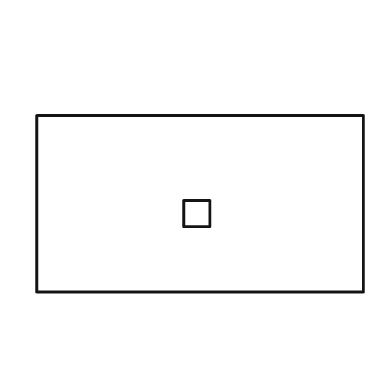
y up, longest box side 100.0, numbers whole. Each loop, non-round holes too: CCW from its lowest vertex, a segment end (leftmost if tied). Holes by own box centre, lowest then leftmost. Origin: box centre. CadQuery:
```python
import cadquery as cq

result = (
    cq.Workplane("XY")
    .moveTo(-50.0, -27.0)
    .lineTo(50.0, -27.0)
    .lineTo(50.0, 27.0)
    .lineTo(-50.0, 27.0)
    .close()
    .moveTo(-5.0, -7.0)
    .lineTo(3.0, -7.0)
    .lineTo(3.0, 1.0)
    .lineTo(-5.0, 1.0)
    .close()
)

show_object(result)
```